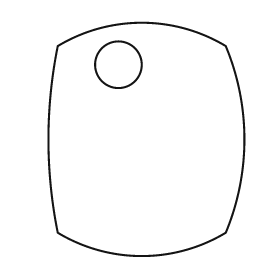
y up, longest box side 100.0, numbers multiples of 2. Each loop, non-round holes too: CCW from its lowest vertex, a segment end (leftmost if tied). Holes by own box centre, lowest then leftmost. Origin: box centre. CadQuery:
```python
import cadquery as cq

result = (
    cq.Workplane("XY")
    .moveTo(-38.0, -40.0)
    .threePointArc((-2.0, -50.0), (34.0, -40.0))
    .threePointArc((42.0, 0.0), (34.0, 40.0))
    .threePointArc((-2.0, 50.0), (-38.0, 40.0))
    .threePointArc((-42.0, 0.0), (-38.0, -40.0))
    .close()
    .moveTo(-12.0, 32.0)
    .circle(10.0)
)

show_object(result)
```